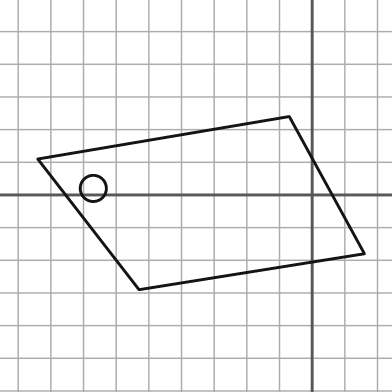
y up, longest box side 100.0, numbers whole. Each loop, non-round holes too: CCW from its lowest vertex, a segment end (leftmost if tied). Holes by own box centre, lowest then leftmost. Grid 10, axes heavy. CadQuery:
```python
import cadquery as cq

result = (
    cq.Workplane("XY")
    .moveTo(-53.0, -29.0)
    .lineTo(16.0, -18.0)
    .lineTo(-7.0, 24.0)
    .lineTo(-84.0, 11.0)
    .close()
    .moveTo(-67.0, 2.0)
    .circle(4.0)
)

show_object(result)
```